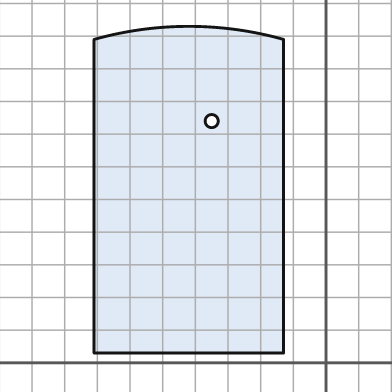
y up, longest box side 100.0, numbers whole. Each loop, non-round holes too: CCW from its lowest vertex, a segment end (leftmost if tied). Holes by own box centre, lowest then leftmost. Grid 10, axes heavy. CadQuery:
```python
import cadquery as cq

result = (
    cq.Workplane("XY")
    .moveTo(-71.0, 3.0)
    .lineTo(-13.0, 3.0)
    .lineTo(-13.0, 99.0)
    .threePointArc((-42.0, 103.0), (-71.0, 99.0))
    .close()
    .moveTo(-35.0, 74.0)
    .circle(2.0)
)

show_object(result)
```